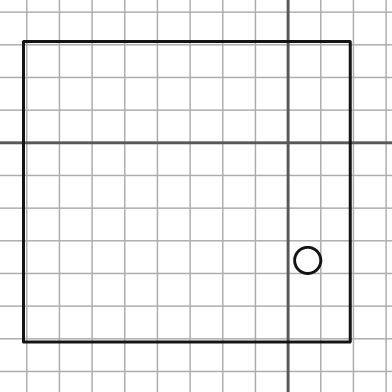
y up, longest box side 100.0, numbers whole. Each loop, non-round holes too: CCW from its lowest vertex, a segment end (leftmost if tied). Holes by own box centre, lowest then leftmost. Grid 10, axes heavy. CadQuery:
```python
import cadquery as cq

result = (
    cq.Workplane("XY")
    .moveTo(-81.0, -61.0)
    .lineTo(19.0, -61.0)
    .lineTo(19.0, 31.0)
    .lineTo(-81.0, 31.0)
    .close()
    .moveTo(6.0, -36.0)
    .circle(4.0)
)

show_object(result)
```